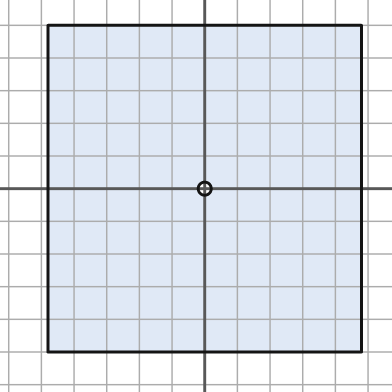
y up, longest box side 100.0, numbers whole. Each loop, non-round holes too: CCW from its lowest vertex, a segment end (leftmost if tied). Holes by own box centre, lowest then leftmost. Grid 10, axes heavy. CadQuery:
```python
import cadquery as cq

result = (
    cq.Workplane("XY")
    .moveTo(-48.0, -50.0)
    .lineTo(48.0, -50.0)
    .lineTo(48.0, 50.0)
    .lineTo(-48.0, 50.0)
    .close()
    .moveTo(0.0, 0.0)
    .circle(2.0)
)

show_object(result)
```